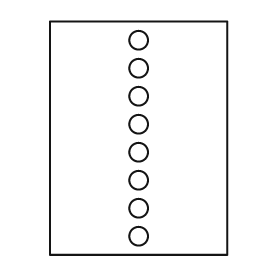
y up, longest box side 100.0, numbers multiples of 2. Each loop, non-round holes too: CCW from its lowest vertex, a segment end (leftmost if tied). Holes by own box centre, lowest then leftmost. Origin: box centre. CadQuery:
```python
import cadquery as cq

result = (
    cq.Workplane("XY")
    .moveTo(-38.0, -50.0)
    .lineTo(38.0, -50.0)
    .lineTo(38.0, 50.0)
    .lineTo(-38.0, 50.0)
    .close()
    .moveTo(0.0, -42.0)
    .circle(4.0)
    .moveTo(0.0, -30.0)
    .circle(4.0)
    .moveTo(0.0, -18.0)
    .circle(4.0)
    .moveTo(0.0, -6.0)
    .circle(4.0)
    .moveTo(0.0, 6.0)
    .circle(4.0)
    .moveTo(0.0, 18.0)
    .circle(4.0)
    .moveTo(0.0, 30.0)
    .circle(4.0)
    .moveTo(0.0, 42.0)
    .circle(4.0)
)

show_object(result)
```